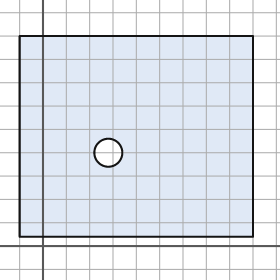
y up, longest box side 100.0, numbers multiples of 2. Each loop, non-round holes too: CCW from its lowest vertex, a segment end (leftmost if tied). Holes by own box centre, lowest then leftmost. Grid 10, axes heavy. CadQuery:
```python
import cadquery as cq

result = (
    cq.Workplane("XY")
    .moveTo(-10.0, 4.0)
    .lineTo(90.0, 4.0)
    .lineTo(90.0, 90.0)
    .lineTo(-10.0, 90.0)
    .close()
    .moveTo(28.0, 40.0)
    .circle(6.0)
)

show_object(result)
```